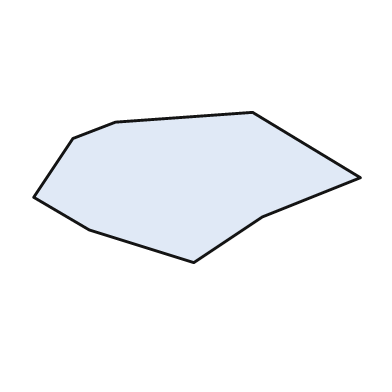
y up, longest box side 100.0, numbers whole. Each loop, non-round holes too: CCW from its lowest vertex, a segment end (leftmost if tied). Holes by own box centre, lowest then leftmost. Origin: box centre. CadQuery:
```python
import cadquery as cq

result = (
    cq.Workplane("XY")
    .moveTo(-1.0, -23.0)
    .lineTo(20.0, -9.0)
    .lineTo(50.0, 3.0)
    .lineTo(17.0, 23.0)
    .lineTo(-25.0, 20.0)
    .lineTo(-38.0, 15.0)
    .lineTo(-50.0, -3.0)
    .lineTo(-33.0, -13.0)
    .close()
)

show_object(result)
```